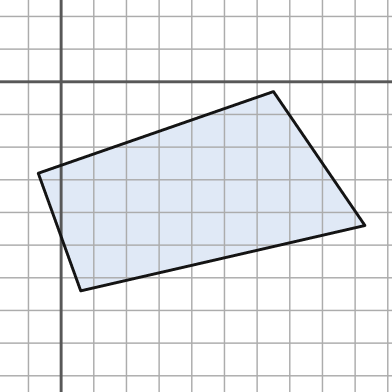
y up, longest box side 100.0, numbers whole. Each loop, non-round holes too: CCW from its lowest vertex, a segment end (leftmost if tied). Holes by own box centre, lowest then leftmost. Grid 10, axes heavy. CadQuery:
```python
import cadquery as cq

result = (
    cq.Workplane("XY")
    .moveTo(6.0, -64.0)
    .lineTo(93.0, -44.0)
    .lineTo(65.0, -3.0)
    .lineTo(-7.0, -28.0)
    .close()
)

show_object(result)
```